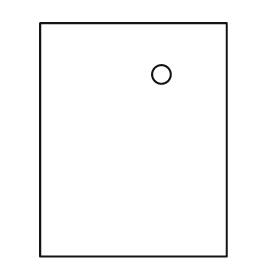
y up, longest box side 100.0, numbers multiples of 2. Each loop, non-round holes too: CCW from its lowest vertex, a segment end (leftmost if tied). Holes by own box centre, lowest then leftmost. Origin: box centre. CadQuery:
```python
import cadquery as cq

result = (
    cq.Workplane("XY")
    .moveTo(-40.0, -50.0)
    .lineTo(40.0, -50.0)
    .lineTo(40.0, 50.0)
    .lineTo(-40.0, 50.0)
    .close()
    .moveTo(12.0, 28.0)
    .circle(4.0)
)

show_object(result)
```